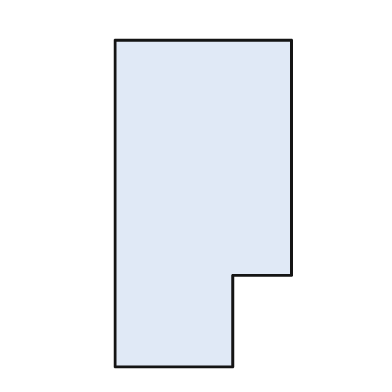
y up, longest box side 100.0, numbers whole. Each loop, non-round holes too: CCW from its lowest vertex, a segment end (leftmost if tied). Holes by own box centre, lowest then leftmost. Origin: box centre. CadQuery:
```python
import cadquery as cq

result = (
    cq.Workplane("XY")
    .moveTo(-27.0, -50.0)
    .lineTo(9.0, -50.0)
    .lineTo(9.0, -22.0)
    .lineTo(27.0, -22.0)
    .lineTo(27.0, 50.0)
    .lineTo(-27.0, 50.0)
    .close()
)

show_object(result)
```